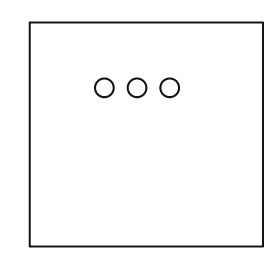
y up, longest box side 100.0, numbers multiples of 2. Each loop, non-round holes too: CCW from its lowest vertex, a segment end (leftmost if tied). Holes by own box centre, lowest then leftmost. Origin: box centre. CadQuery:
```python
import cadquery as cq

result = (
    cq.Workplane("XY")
    .moveTo(-50.0, -48.0)
    .lineTo(50.0, -48.0)
    .lineTo(50.0, 48.0)
    .lineTo(-50.0, 48.0)
    .close()
    .moveTo(-18.0, 20.0)
    .circle(4.0)
    .moveTo(-4.0, 20.0)
    .circle(4.0)
    .moveTo(10.0, 20.0)
    .circle(4.0)
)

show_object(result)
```